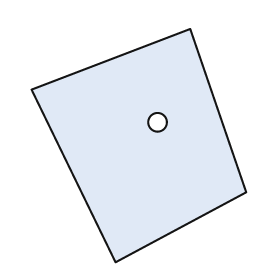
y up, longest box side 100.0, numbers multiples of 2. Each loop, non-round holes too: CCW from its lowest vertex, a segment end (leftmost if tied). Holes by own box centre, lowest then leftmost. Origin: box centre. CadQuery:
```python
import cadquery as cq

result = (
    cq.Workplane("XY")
    .moveTo(-10.0, -50.0)
    .lineTo(46.0, -20.0)
    .lineTo(22.0, 50.0)
    .lineTo(-46.0, 24.0)
    .close()
    .moveTo(8.0, 10.0)
    .circle(4.0)
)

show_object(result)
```